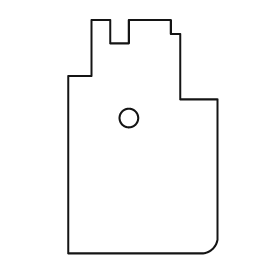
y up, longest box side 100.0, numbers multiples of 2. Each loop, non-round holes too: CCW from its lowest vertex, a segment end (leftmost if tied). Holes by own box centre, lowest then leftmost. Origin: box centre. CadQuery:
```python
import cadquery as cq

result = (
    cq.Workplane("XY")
    .moveTo(-32.0, -50.0)
    .lineTo(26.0, -50.0)
    .threePointArc((30.0, -48.0), (32.0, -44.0))
    .lineTo(32.0, 16.0)
    .lineTo(16.0, 16.0)
    .lineTo(16.0, 44.0)
    .lineTo(12.0, 44.0)
    .lineTo(12.0, 50.0)
    .lineTo(-6.0, 50.0)
    .lineTo(-6.0, 40.0)
    .lineTo(-14.0, 40.0)
    .lineTo(-14.0, 50.0)
    .lineTo(-22.0, 50.0)
    .lineTo(-22.0, 26.0)
    .lineTo(-32.0, 26.0)
    .close()
    .moveTo(-6.0, 8.0)
    .circle(4.0)
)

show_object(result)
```